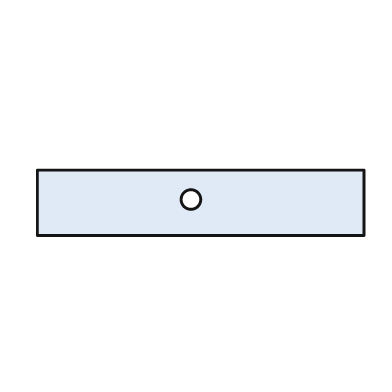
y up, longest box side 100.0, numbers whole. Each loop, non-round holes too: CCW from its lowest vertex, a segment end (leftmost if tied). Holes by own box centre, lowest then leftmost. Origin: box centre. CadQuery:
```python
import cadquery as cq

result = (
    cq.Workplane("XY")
    .moveTo(-50.0, -10.0)
    .lineTo(50.0, -10.0)
    .lineTo(50.0, 10.0)
    .lineTo(-50.0, 10.0)
    .close()
    .moveTo(-3.0, 1.0)
    .circle(3.0)
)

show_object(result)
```